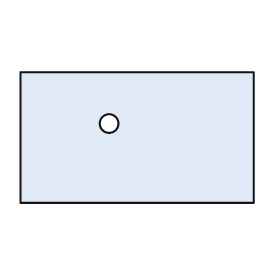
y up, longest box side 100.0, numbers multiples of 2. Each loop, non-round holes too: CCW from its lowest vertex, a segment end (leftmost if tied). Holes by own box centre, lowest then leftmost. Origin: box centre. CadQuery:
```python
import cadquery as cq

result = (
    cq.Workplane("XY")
    .moveTo(-50.0, -28.0)
    .lineTo(50.0, -28.0)
    .lineTo(50.0, 28.0)
    .lineTo(-50.0, 28.0)
    .close()
    .moveTo(-12.0, 6.0)
    .circle(4.0)
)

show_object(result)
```